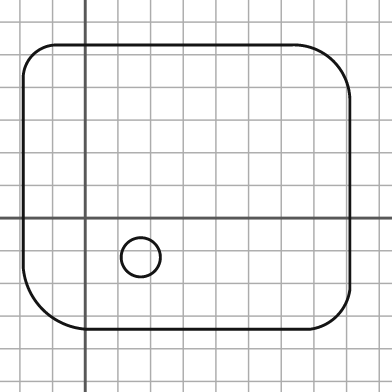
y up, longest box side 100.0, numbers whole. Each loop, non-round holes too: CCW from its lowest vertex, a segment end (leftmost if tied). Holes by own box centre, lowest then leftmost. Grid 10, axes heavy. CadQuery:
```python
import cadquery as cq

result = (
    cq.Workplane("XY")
    .moveTo(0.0, -34.0)
    .lineTo(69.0, -34.0)
    .threePointArc((77.0, -30.0), (81.0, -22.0))
    .lineTo(81.0, 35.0)
    .threePointArc((76.0, 48.0), (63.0, 53.0))
    .lineTo(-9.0, 53.0)
    .threePointArc((-16.0, 50.0), (-19.0, 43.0))
    .lineTo(-19.0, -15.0)
    .threePointArc((-13.0, -28.0), (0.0, -34.0))
    .close()
    .moveTo(17.0, -12.0)
    .circle(6.0)
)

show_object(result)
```